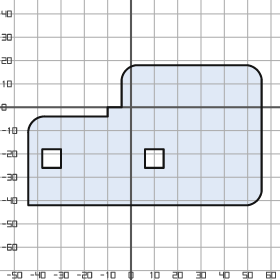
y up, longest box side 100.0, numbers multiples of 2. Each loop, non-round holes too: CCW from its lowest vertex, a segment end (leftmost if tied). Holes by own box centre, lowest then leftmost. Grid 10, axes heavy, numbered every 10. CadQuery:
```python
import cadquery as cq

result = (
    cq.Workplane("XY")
    .moveTo(-44.0, -42.0)
    .lineTo(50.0, -42.0)
    .threePointArc((54.0, -40.0), (56.0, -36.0))
    .lineTo(56.0, 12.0)
    .threePointArc((54.0, 16.0), (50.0, 18.0))
    .lineTo(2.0, 18.0)
    .threePointArc((-2.0, 16.0), (-4.0, 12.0))
    .lineTo(-4.0, 0.0)
    .lineTo(-10.0, 0.0)
    .lineTo(-10.0, -4.0)
    .lineTo(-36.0, -4.0)
    .threePointArc((-42.0, -6.0), (-44.0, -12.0))
    .close()
    .moveTo(-38.0, -26.0)
    .lineTo(-30.0, -26.0)
    .lineTo(-30.0, -18.0)
    .lineTo(-38.0, -18.0)
    .close()
    .moveTo(6.0, -26.0)
    .lineTo(14.0, -26.0)
    .lineTo(14.0, -18.0)
    .lineTo(6.0, -18.0)
    .close()
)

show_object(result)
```